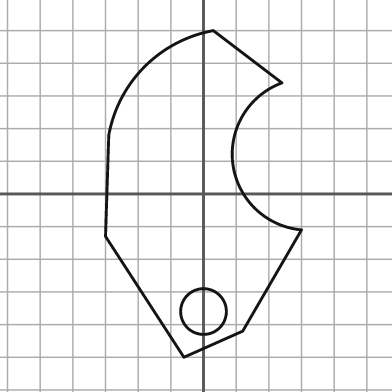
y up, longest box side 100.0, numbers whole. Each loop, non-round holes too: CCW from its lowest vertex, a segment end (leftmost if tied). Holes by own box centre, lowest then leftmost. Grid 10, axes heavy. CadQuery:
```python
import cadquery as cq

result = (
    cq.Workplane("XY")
    .moveTo(-6.0, -50.0)
    .lineTo(12.0, -42.0)
    .lineTo(30.0, -11.0)
    .threePointArc((9.0, 9.0), (24.0, 34.0))
    .lineTo(3.0, 50.0)
    .threePointArc((-18.0, 39.0), (-29.0, 18.0))
    .lineTo(-30.0, -13.0)
    .close()
    .moveTo(0.0, -36.0)
    .circle(7.0)
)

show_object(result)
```